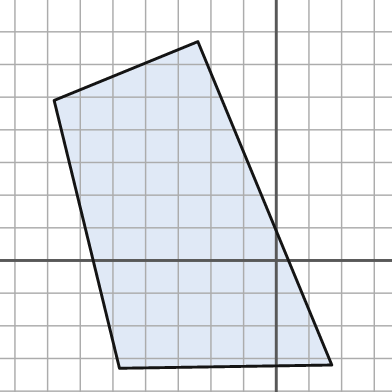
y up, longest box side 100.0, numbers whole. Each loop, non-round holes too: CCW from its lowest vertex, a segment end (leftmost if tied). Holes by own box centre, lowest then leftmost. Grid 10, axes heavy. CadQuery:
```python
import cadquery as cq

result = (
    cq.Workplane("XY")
    .moveTo(-48.0, -33.0)
    .lineTo(17.0, -32.0)
    .lineTo(-24.0, 67.0)
    .lineTo(-68.0, 49.0)
    .close()
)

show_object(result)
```